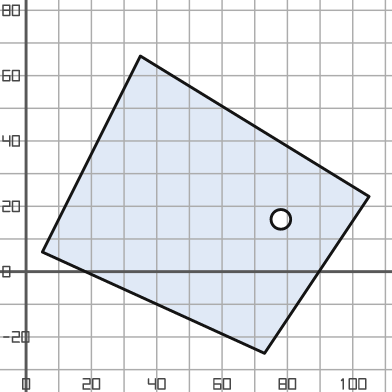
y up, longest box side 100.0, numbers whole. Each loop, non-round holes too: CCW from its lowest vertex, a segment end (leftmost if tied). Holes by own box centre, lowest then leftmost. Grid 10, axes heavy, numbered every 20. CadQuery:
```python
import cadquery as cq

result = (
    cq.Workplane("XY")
    .moveTo(73.0, -25.0)
    .lineTo(105.0, 23.0)
    .lineTo(35.0, 66.0)
    .lineTo(5.0, 6.0)
    .close()
    .moveTo(78.0, 16.0)
    .circle(3.0)
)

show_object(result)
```